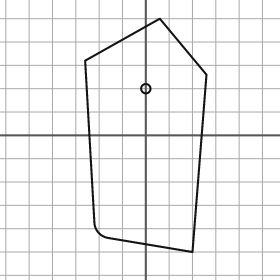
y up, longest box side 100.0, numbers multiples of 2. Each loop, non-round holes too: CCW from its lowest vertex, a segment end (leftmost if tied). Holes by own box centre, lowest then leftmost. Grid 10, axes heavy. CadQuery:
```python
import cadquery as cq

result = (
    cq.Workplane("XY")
    .moveTo(20.0, -50.0)
    .lineTo(26.0, 26.0)
    .lineTo(6.0, 50.0)
    .lineTo(-26.0, 32.0)
    .lineTo(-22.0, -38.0)
    .threePointArc((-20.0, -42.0), (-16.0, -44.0))
    .close()
    .moveTo(0.0, 20.0)
    .circle(2.0)
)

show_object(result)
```